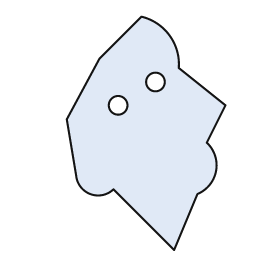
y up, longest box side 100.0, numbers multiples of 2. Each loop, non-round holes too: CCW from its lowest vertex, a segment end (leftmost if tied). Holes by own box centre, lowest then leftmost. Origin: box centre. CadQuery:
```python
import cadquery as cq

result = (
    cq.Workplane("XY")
    .moveTo(12.0, -50.0)
    .lineTo(22.0, -26.0)
    .threePointArc((30.0, -16.0), (26.0, -4.0))
    .lineTo(34.0, 12.0)
    .lineTo(14.0, 28.0)
    .threePointArc((10.0, 42.0), (-2.0, 50.0))
    .lineTo(-20.0, 32.0)
    .lineTo(-34.0, 6.0)
    .lineTo(-30.0, -18.0)
    .threePointArc((-24.0, -26.0), (-14.0, -24.0))
    .close()
    .moveTo(-12.0, 12.0)
    .circle(4.0)
    .moveTo(4.0, 22.0)
    .circle(4.0)
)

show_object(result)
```